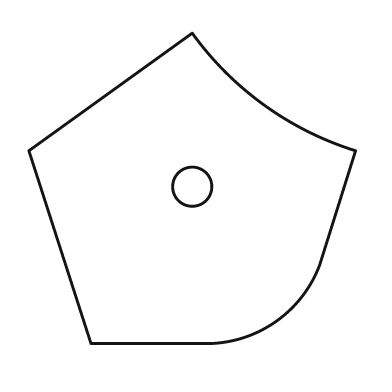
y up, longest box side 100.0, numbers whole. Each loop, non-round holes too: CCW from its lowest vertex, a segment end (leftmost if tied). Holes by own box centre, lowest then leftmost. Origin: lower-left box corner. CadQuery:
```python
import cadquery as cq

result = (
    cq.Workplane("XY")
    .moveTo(19.0, 0.0)
    .lineTo(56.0, 0.0)
    .threePointArc((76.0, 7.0), (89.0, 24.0))
    .lineTo(100.0, 59.0)
    .threePointArc((72.0, 73.0), (50.0, 95.0))
    .lineTo(0.0, 59.0)
    .close()
    .moveTo(50.0, 48.0)
    .circle(6.0)
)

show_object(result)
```